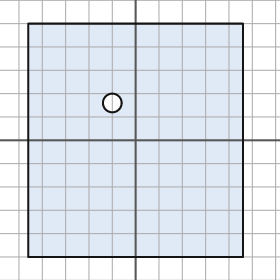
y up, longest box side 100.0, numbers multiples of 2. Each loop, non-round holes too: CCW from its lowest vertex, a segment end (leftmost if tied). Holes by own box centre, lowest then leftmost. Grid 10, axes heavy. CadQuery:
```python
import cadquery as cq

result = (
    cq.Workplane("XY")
    .moveTo(-46.0, -50.0)
    .lineTo(46.0, -50.0)
    .lineTo(46.0, 50.0)
    .lineTo(-46.0, 50.0)
    .close()
    .moveTo(-10.0, 16.0)
    .circle(4.0)
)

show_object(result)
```